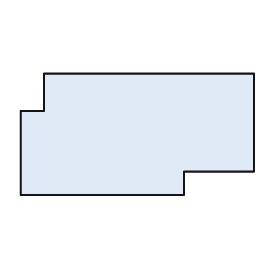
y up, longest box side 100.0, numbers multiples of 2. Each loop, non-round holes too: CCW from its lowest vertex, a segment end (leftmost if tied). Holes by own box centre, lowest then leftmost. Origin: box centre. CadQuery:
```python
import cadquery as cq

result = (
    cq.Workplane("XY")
    .moveTo(-50.0, -26.0)
    .lineTo(20.0, -26.0)
    .lineTo(20.0, -16.0)
    .lineTo(50.0, -16.0)
    .lineTo(50.0, 26.0)
    .lineTo(-40.0, 26.0)
    .lineTo(-40.0, 10.0)
    .lineTo(-50.0, 10.0)
    .close()
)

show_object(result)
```